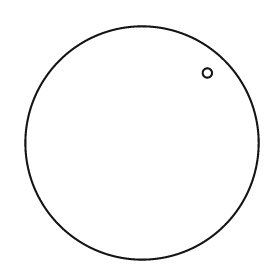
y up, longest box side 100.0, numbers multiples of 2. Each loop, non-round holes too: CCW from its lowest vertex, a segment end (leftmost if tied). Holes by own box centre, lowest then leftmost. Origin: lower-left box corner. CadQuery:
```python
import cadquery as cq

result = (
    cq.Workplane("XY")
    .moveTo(50.0, 50.0)
    .circle(50.0)
    .moveTo(78.0, 80.0)
    .circle(2.0)
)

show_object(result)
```